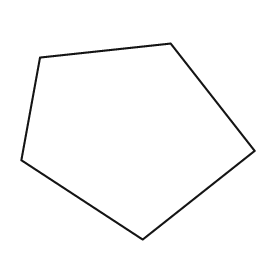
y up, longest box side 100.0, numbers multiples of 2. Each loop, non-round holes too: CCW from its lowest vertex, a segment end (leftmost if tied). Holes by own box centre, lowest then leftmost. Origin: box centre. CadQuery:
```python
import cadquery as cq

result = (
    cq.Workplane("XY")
    .moveTo(2.0, -42.0)
    .lineTo(50.0, -4.0)
    .lineTo(14.0, 42.0)
    .lineTo(-42.0, 36.0)
    .lineTo(-50.0, -8.0)
    .close()
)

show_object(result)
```